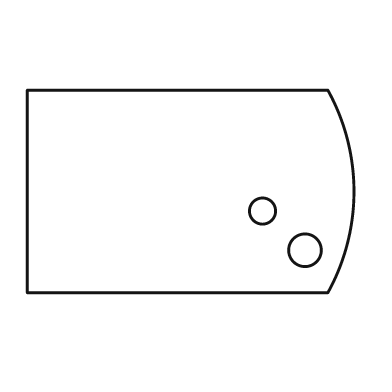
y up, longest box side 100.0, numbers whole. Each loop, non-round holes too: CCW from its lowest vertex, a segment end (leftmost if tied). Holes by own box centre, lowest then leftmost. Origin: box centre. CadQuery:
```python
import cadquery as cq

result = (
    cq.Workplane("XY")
    .moveTo(-50.0, -31.0)
    .lineTo(42.0, -31.0)
    .threePointArc((50.0, 0.0), (42.0, 31.0))
    .lineTo(-50.0, 31.0)
    .close()
    .moveTo(35.0, -18.0)
    .circle(5.0)
    .moveTo(22.0, -6.0)
    .circle(4.0)
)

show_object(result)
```